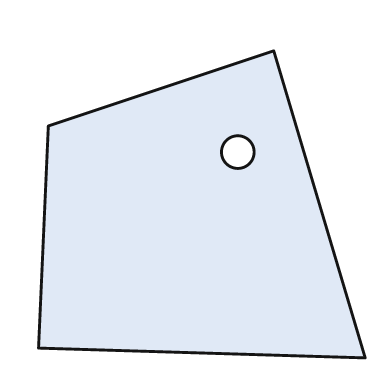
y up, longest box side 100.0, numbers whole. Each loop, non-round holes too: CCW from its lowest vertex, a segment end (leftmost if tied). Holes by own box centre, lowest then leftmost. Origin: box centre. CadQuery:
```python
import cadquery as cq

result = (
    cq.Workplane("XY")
    .moveTo(50.0, -47.0)
    .lineTo(22.0, 47.0)
    .lineTo(-47.0, 24.0)
    .lineTo(-50.0, -44.0)
    .close()
    .moveTo(11.0, 16.0)
    .circle(5.0)
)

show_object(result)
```